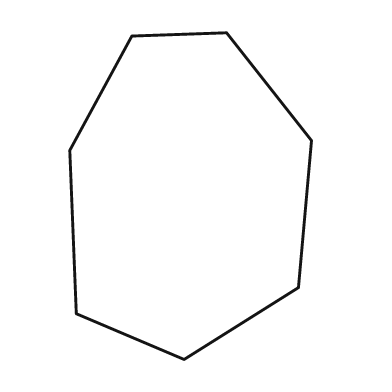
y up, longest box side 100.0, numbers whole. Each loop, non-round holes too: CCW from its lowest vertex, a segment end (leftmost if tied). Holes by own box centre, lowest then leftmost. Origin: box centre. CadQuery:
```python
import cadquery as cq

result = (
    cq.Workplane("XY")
    .moveTo(-2.0, -50.0)
    .lineTo(33.0, -28.0)
    .lineTo(37.0, 17.0)
    .lineTo(11.0, 50.0)
    .lineTo(-18.0, 49.0)
    .lineTo(-37.0, 14.0)
    .lineTo(-35.0, -36.0)
    .close()
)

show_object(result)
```